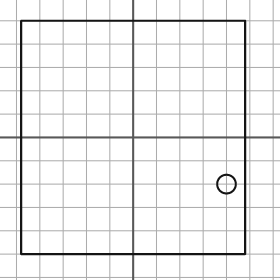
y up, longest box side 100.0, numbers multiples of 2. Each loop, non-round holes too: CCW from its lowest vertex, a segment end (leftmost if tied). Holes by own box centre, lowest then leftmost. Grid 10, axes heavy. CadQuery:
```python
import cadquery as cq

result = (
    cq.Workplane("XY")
    .moveTo(-48.0, -50.0)
    .lineTo(48.0, -50.0)
    .lineTo(48.0, 50.0)
    .lineTo(-48.0, 50.0)
    .close()
    .moveTo(40.0, -20.0)
    .circle(4.0)
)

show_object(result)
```